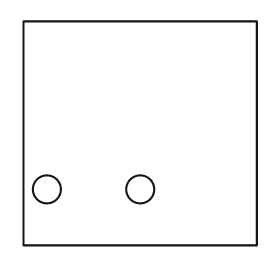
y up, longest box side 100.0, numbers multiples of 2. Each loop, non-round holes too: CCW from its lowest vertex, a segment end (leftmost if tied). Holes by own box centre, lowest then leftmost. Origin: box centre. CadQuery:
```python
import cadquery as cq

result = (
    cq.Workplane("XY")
    .moveTo(-50.0, -48.0)
    .lineTo(50.0, -48.0)
    .lineTo(50.0, 48.0)
    .lineTo(-50.0, 48.0)
    .close()
    .moveTo(-40.0, -24.0)
    .circle(6.0)
    .moveTo(0.0, -24.0)
    .circle(6.0)
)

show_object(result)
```